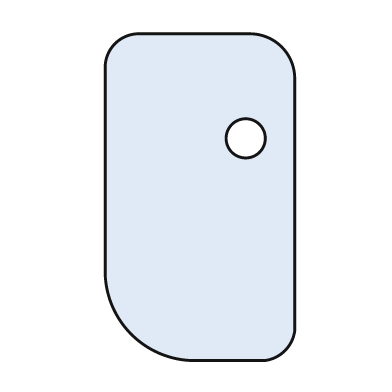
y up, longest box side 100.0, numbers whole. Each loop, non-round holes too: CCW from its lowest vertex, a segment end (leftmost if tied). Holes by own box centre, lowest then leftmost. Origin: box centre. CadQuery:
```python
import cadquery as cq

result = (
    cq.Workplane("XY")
    .moveTo(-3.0, -50.0)
    .lineTo(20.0, -50.0)
    .threePointArc((26.0, -47.0), (29.0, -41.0))
    .lineTo(29.0, 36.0)
    .threePointArc((25.0, 46.0), (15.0, 50.0))
    .lineTo(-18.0, 50.0)
    .threePointArc((-26.0, 47.0), (-29.0, 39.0))
    .lineTo(-29.0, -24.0)
    .threePointArc((-21.0, -42.0), (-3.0, -50.0))
    .close()
    .moveTo(14.0, 18.0)
    .circle(6.0)
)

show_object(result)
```